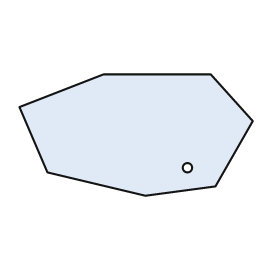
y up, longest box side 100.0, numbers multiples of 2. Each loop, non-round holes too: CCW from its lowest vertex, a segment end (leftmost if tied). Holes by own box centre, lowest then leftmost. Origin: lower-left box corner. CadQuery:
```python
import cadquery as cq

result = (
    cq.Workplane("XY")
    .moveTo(54.0, 0.0)
    .lineTo(84.0, 4.0)
    .lineTo(100.0, 32.0)
    .lineTo(82.0, 52.0)
    .lineTo(36.0, 52.0)
    .lineTo(0.0, 38.0)
    .lineTo(12.0, 10.0)
    .close()
    .moveTo(72.0, 12.0)
    .circle(2.0)
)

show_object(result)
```